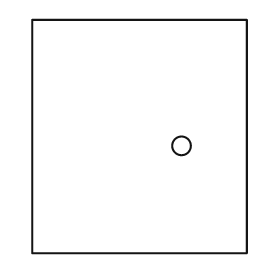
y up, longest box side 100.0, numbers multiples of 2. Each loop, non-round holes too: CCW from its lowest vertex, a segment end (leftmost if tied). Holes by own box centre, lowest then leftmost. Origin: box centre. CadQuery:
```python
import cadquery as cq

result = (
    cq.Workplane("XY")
    .moveTo(-46.0, -50.0)
    .lineTo(46.0, -50.0)
    .lineTo(46.0, 50.0)
    .lineTo(-46.0, 50.0)
    .close()
    .moveTo(18.0, -4.0)
    .circle(4.0)
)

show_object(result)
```